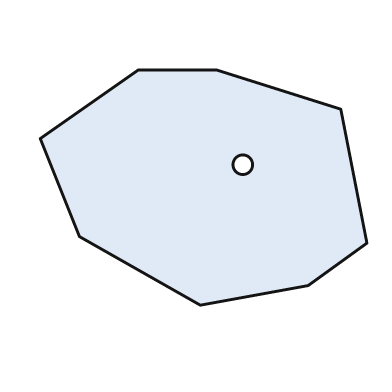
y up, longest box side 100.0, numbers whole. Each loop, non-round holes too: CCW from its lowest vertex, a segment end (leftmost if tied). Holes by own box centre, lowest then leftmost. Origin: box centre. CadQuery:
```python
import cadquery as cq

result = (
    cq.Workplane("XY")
    .moveTo(-1.0, -36.0)
    .lineTo(32.0, -30.0)
    .lineTo(50.0, -17.0)
    .lineTo(42.0, 24.0)
    .lineTo(4.0, 36.0)
    .lineTo(-20.0, 36.0)
    .lineTo(-50.0, 15.0)
    .lineTo(-38.0, -15.0)
    .close()
    .moveTo(12.0, 7.0)
    .circle(3.0)
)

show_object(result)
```